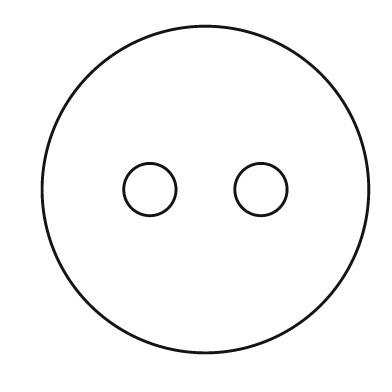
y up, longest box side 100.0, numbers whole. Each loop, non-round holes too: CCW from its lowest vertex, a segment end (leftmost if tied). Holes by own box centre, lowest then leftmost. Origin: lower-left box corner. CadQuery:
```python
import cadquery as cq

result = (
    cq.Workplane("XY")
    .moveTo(50.0, 50.0)
    .circle(50.0)
    .moveTo(33.0, 50.0)
    .circle(8.0)
    .moveTo(67.0, 50.0)
    .circle(8.0)
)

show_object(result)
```